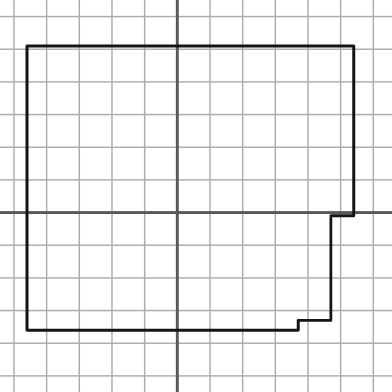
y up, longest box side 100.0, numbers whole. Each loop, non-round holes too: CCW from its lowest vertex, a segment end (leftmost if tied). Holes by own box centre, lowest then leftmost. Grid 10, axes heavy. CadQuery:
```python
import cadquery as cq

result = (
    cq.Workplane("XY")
    .moveTo(-46.0, -36.0)
    .lineTo(37.0, -36.0)
    .lineTo(37.0, -33.0)
    .lineTo(47.0, -33.0)
    .lineTo(47.0, -1.0)
    .lineTo(54.0, -1.0)
    .lineTo(54.0, 51.0)
    .lineTo(-46.0, 51.0)
    .close()
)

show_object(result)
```